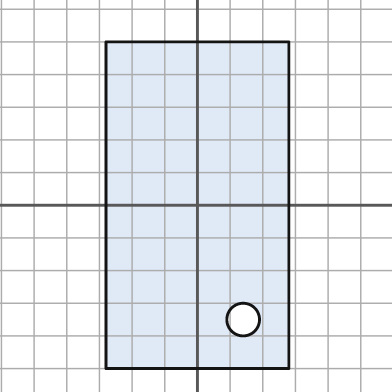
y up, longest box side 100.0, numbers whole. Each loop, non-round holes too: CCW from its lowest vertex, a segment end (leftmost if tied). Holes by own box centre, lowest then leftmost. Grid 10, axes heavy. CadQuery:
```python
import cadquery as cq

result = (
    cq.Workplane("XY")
    .moveTo(-28.0, -50.0)
    .lineTo(28.0, -50.0)
    .lineTo(28.0, 50.0)
    .lineTo(-28.0, 50.0)
    .close()
    .moveTo(14.0, -35.0)
    .circle(5.0)
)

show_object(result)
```